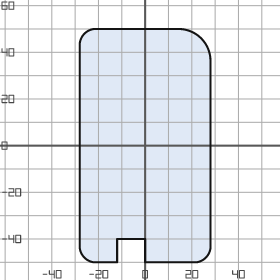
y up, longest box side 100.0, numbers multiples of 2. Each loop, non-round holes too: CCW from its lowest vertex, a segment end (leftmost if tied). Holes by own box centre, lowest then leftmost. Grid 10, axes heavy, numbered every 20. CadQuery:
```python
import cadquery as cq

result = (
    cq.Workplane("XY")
    .moveTo(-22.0, -50.0)
    .lineTo(-12.0, -50.0)
    .lineTo(-12.0, -40.0)
    .lineTo(0.0, -40.0)
    .lineTo(0.0, -50.0)
    .lineTo(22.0, -50.0)
    .threePointArc((26.0, -48.0), (28.0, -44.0))
    .lineTo(28.0, 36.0)
    .threePointArc((24.0, 46.0), (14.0, 50.0))
    .lineTo(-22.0, 50.0)
    .threePointArc((-26.0, 48.0), (-28.0, 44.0))
    .lineTo(-28.0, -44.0)
    .threePointArc((-26.0, -48.0), (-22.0, -50.0))
    .close()
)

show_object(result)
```